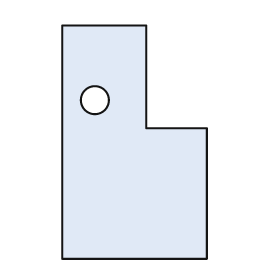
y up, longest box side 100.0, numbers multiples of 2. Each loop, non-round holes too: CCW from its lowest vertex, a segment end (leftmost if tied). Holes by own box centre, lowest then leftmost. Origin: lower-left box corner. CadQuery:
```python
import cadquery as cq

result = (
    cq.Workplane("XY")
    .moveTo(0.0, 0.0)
    .lineTo(62.0, 0.0)
    .lineTo(62.0, 56.0)
    .lineTo(36.0, 56.0)
    .lineTo(36.0, 100.0)
    .lineTo(0.0, 100.0)
    .close()
    .moveTo(14.0, 68.0)
    .circle(6.0)
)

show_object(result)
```